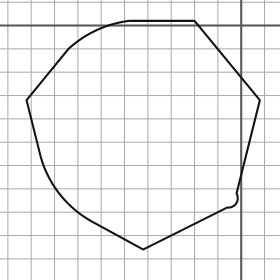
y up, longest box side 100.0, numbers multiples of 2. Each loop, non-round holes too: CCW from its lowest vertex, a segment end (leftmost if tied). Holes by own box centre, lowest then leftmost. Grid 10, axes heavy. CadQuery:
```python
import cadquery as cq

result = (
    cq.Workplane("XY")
    .moveTo(-42.0, -96.0)
    .lineTo(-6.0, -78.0)
    .threePointArc((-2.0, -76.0), (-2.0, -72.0))
    .lineTo(8.0, -32.0)
    .lineTo(-20.0, 2.0)
    .lineTo(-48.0, 2.0)
    .threePointArc((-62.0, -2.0), (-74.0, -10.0))
    .lineTo(-92.0, -32.0)
    .lineTo(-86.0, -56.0)
    .threePointArc((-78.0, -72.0), (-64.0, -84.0))
    .close()
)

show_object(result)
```